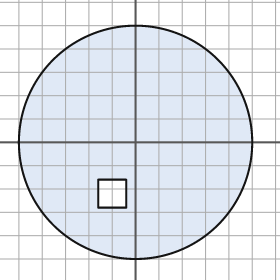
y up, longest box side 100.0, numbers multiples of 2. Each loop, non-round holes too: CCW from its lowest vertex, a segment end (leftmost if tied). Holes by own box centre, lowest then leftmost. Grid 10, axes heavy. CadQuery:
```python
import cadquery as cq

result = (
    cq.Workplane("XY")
    .moveTo(0.0, 0.0)
    .circle(50.0)
    .moveTo(-16.0, -28.0)
    .lineTo(-4.0, -28.0)
    .lineTo(-4.0, -16.0)
    .lineTo(-16.0, -16.0)
    .close()
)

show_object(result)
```